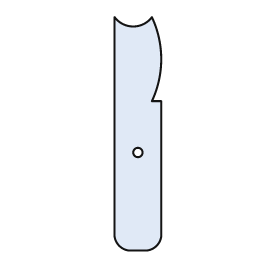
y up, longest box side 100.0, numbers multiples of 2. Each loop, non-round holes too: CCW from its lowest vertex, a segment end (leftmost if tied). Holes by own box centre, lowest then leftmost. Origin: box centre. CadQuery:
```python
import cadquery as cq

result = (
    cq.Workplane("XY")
    .moveTo(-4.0, -50.0)
    .lineTo(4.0, -50.0)
    .threePointArc((8.0, -48.0), (10.0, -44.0))
    .lineTo(10.0, 14.0)
    .lineTo(6.0, 14.0)
    .threePointArc((10.0, 32.0), (6.0, 50.0))
    .threePointArc((-2.0, 46.0), (-10.0, 50.0))
    .lineTo(-10.0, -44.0)
    .threePointArc((-8.0, -48.0), (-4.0, -50.0))
    .close()
    .moveTo(0.0, -8.0)
    .circle(2.0)
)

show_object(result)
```